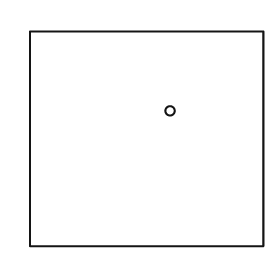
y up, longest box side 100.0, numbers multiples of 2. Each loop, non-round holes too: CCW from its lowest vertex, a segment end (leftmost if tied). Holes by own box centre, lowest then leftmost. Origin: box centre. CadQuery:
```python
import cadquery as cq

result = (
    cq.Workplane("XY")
    .moveTo(-50.0, -46.0)
    .lineTo(50.0, -46.0)
    .lineTo(50.0, 46.0)
    .lineTo(-50.0, 46.0)
    .close()
    .moveTo(10.0, 12.0)
    .circle(2.0)
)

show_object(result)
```